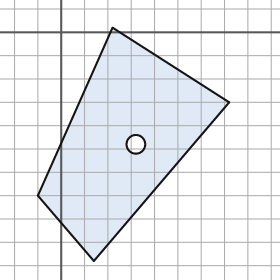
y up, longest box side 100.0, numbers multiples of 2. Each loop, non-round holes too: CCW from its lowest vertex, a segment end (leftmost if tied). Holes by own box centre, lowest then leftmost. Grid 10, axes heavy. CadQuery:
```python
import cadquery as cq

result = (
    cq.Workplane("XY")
    .moveTo(14.0, -98.0)
    .lineTo(72.0, -30.0)
    .lineTo(22.0, 2.0)
    .lineTo(-10.0, -70.0)
    .close()
    .moveTo(32.0, -48.0)
    .circle(4.0)
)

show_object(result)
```